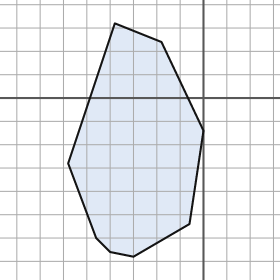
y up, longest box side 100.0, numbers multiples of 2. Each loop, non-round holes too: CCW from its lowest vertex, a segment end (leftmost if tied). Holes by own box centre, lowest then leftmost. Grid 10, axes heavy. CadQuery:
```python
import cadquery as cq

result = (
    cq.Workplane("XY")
    .moveTo(-30.0, -68.0)
    .lineTo(-6.0, -54.0)
    .lineTo(0.0, -14.0)
    .lineTo(-18.0, 24.0)
    .lineTo(-38.0, 32.0)
    .lineTo(-58.0, -28.0)
    .lineTo(-46.0, -60.0)
    .lineTo(-40.0, -66.0)
    .close()
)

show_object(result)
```